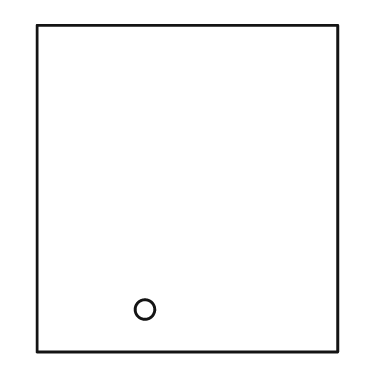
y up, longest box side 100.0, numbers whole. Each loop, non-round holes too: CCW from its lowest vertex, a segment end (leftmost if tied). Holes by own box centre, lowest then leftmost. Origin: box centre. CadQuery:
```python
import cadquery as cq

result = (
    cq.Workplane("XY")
    .moveTo(-46.0, -50.0)
    .lineTo(46.0, -50.0)
    .lineTo(46.0, 50.0)
    .lineTo(-46.0, 50.0)
    .close()
    .moveTo(-13.0, -37.0)
    .circle(3.0)
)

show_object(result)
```